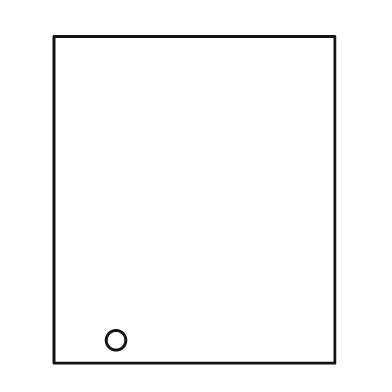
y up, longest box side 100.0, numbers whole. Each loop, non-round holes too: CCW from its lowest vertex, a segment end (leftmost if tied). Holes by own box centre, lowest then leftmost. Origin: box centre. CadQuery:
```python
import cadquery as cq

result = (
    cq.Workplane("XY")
    .moveTo(-43.0, -50.0)
    .lineTo(43.0, -50.0)
    .lineTo(43.0, 50.0)
    .lineTo(-43.0, 50.0)
    .close()
    .moveTo(-24.0, -43.0)
    .circle(3.0)
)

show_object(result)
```